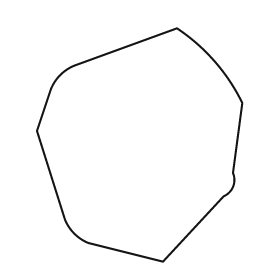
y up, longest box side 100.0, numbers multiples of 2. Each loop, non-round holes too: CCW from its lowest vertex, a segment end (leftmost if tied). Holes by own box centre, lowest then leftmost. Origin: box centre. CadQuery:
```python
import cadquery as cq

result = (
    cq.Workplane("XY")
    .moveTo(10.0, -50.0)
    .lineTo(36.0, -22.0)
    .threePointArc((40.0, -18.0), (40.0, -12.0))
    .lineTo(44.0, 18.0)
    .threePointArc((32.0, 36.0), (16.0, 50.0))
    .lineTo(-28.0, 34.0)
    .threePointArc((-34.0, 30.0), (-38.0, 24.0))
    .lineTo(-44.0, 6.0)
    .lineTo(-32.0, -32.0)
    .threePointArc((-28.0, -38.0), (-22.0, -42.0))
    .close()
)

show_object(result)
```